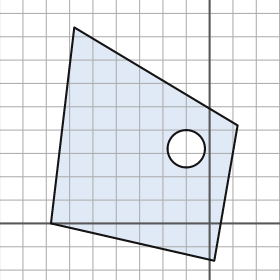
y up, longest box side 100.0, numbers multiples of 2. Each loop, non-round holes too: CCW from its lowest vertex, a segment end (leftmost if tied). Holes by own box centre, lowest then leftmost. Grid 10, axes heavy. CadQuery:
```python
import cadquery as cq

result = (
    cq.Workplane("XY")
    .moveTo(2.0, -16.0)
    .lineTo(12.0, 42.0)
    .lineTo(-58.0, 84.0)
    .lineTo(-68.0, 0.0)
    .close()
    .moveTo(-10.0, 32.0)
    .circle(8.0)
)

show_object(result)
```